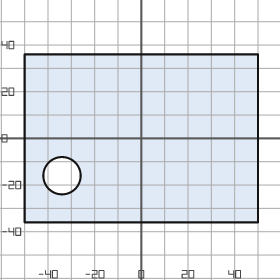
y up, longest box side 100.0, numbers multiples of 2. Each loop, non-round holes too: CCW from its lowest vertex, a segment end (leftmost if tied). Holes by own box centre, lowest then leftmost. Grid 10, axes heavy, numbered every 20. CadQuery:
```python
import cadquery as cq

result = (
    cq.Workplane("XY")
    .moveTo(-50.0, -36.0)
    .lineTo(50.0, -36.0)
    .lineTo(50.0, 36.0)
    .lineTo(-50.0, 36.0)
    .close()
    .moveTo(-34.0, -16.0)
    .circle(8.0)
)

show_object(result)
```